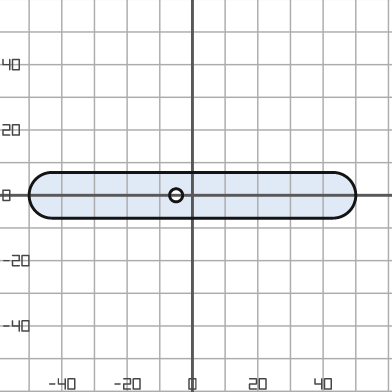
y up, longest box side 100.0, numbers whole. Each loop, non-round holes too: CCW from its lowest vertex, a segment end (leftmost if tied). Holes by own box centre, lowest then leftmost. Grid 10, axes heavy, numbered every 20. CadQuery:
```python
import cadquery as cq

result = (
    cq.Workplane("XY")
    .moveTo(-43.0, -7.0)
    .lineTo(43.0, -7.0)
    .threePointArc((50.0, 0.0), (43.0, 7.0))
    .lineTo(-43.0, 7.0)
    .threePointArc((-50.0, 0.0), (-43.0, -7.0))
    .close()
    .moveTo(-5.0, 0.0)
    .circle(2.0)
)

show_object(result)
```